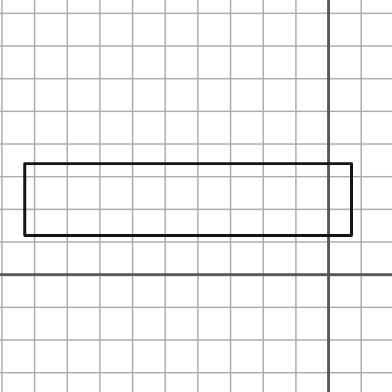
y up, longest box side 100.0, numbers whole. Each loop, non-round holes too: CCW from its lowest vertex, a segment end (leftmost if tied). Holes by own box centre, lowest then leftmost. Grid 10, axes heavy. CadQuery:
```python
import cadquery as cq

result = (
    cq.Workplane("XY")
    .moveTo(-93.0, 12.0)
    .lineTo(7.0, 12.0)
    .lineTo(7.0, 34.0)
    .lineTo(-93.0, 34.0)
    .close()
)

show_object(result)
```